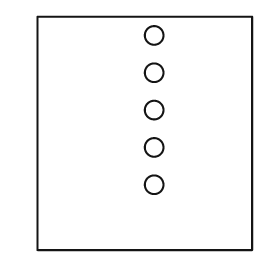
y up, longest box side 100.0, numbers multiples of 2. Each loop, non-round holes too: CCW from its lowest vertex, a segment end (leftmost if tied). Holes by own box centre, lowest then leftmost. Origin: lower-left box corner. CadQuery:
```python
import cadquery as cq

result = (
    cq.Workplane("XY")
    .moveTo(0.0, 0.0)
    .lineTo(92.0, 0.0)
    .lineTo(92.0, 100.0)
    .lineTo(0.0, 100.0)
    .close()
    .moveTo(50.0, 28.0)
    .circle(4.0)
    .moveTo(50.0, 44.0)
    .circle(4.0)
    .moveTo(50.0, 60.0)
    .circle(4.0)
    .moveTo(50.0, 76.0)
    .circle(4.0)
    .moveTo(50.0, 92.0)
    .circle(4.0)
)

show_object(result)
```